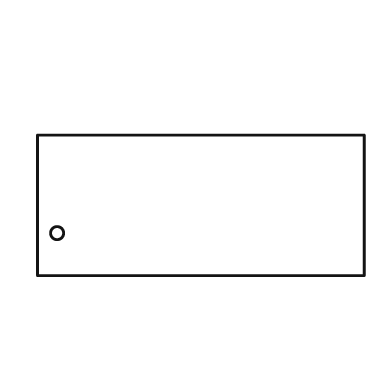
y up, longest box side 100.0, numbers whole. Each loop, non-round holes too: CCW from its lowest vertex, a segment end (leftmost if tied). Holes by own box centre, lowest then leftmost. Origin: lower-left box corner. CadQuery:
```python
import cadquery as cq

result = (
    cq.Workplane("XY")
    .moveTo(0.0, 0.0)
    .lineTo(100.0, 0.0)
    .lineTo(100.0, 43.0)
    .lineTo(0.0, 43.0)
    .close()
    .moveTo(6.0, 13.0)
    .circle(2.0)
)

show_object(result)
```